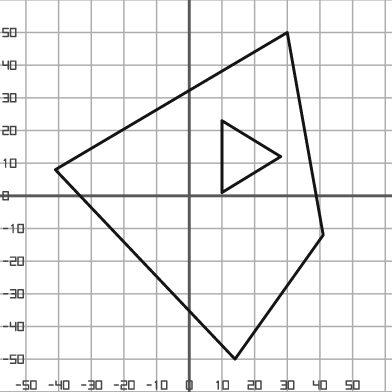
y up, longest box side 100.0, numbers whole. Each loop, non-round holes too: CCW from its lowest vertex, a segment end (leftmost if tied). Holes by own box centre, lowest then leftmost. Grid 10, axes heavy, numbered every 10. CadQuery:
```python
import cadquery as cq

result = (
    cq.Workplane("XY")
    .moveTo(14.0, -50.0)
    .lineTo(41.0, -12.0)
    .lineTo(30.0, 50.0)
    .lineTo(-41.0, 8.0)
    .close()
    .moveTo(10.0, 1.0)
    .lineTo(28.0, 12.0)
    .lineTo(10.0, 23.0)
    .close()
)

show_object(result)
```